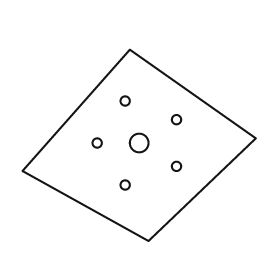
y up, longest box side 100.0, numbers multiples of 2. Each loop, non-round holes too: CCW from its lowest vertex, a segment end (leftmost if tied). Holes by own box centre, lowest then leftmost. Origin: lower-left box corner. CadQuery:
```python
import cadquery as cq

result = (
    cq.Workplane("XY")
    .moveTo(54.0, 0.0)
    .lineTo(100.0, 44.0)
    .lineTo(46.0, 82.0)
    .lineTo(0.0, 30.0)
    .close()
    .moveTo(44.0, 24.0)
    .circle(2.0)
    .moveTo(66.0, 32.0)
    .circle(2.0)
    .moveTo(32.0, 42.0)
    .circle(2.0)
    .moveTo(50.0, 42.0)
    .circle(4.0)
    .moveTo(66.0, 52.0)
    .circle(2.0)
    .moveTo(44.0, 60.0)
    .circle(2.0)
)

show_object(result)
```